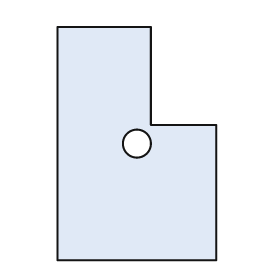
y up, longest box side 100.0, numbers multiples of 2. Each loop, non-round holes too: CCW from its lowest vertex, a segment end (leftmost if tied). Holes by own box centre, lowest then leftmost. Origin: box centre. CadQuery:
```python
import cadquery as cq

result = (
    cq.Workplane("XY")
    .moveTo(-34.0, -50.0)
    .lineTo(34.0, -50.0)
    .lineTo(34.0, 8.0)
    .lineTo(6.0, 8.0)
    .lineTo(6.0, 50.0)
    .lineTo(-34.0, 50.0)
    .close()
    .moveTo(0.0, 0.0)
    .circle(6.0)
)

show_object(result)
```